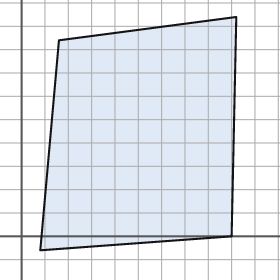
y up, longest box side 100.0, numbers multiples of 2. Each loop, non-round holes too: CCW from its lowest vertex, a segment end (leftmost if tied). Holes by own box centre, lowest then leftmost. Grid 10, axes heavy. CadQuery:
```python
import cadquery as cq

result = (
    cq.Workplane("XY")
    .moveTo(8.0, -6.0)
    .lineTo(90.0, 0.0)
    .lineTo(92.0, 94.0)
    .lineTo(16.0, 84.0)
    .close()
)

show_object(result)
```